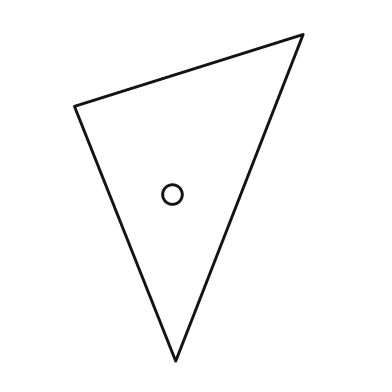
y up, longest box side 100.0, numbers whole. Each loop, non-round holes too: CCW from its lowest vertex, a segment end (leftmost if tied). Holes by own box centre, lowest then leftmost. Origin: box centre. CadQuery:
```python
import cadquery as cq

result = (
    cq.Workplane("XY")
    .moveTo(-4.0, -50.0)
    .lineTo(35.0, 50.0)
    .lineTo(-35.0, 28.0)
    .close()
    .moveTo(-5.0, 1.0)
    .circle(3.0)
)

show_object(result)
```